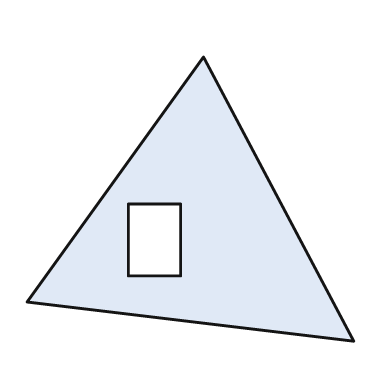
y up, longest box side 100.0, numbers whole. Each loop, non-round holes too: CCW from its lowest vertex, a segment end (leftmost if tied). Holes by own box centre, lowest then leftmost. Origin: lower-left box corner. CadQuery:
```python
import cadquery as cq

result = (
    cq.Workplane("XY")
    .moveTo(100.0, 0.0)
    .lineTo(54.0, 87.0)
    .lineTo(0.0, 12.0)
    .close()
    .moveTo(31.0, 20.0)
    .lineTo(47.0, 20.0)
    .lineTo(47.0, 42.0)
    .lineTo(31.0, 42.0)
    .close()
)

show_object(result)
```